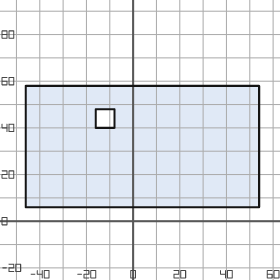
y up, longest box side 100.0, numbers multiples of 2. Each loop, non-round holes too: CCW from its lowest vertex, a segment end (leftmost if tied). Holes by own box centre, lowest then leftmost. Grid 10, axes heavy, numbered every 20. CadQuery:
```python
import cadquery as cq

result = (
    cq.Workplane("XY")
    .moveTo(-46.0, 6.0)
    .lineTo(54.0, 6.0)
    .lineTo(54.0, 58.0)
    .lineTo(-46.0, 58.0)
    .close()
    .moveTo(-16.0, 40.0)
    .lineTo(-8.0, 40.0)
    .lineTo(-8.0, 48.0)
    .lineTo(-16.0, 48.0)
    .close()
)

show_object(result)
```